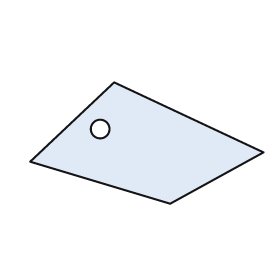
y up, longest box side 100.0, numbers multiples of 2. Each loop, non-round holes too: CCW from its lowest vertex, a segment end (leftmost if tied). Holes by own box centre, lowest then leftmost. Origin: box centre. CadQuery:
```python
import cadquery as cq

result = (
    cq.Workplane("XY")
    .moveTo(10.0, -26.0)
    .lineTo(50.0, -4.0)
    .lineTo(-14.0, 26.0)
    .lineTo(-50.0, -8.0)
    .close()
    .moveTo(-20.0, 6.0)
    .circle(4.0)
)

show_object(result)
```